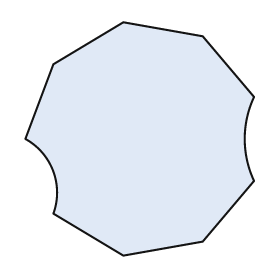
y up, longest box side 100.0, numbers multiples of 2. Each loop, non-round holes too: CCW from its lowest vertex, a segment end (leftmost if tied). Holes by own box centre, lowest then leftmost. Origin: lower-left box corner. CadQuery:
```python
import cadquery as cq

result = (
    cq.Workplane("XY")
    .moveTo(42.0, 0.0)
    .lineTo(76.0, 6.0)
    .lineTo(98.0, 32.0)
    .threePointArc((94.0, 50.0), (98.0, 68.0))
    .lineTo(76.0, 94.0)
    .lineTo(42.0, 100.0)
    .lineTo(12.0, 82.0)
    .lineTo(0.0, 50.0)
    .threePointArc((12.0, 36.0), (12.0, 18.0))
    .close()
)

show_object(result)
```